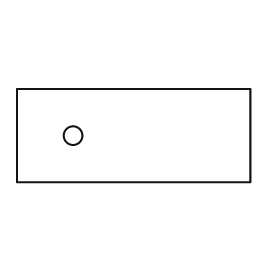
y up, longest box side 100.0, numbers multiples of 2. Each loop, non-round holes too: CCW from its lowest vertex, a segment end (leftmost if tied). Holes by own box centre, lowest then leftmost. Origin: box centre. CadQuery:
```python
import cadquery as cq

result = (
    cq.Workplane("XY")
    .moveTo(-50.0, -20.0)
    .lineTo(50.0, -20.0)
    .lineTo(50.0, 20.0)
    .lineTo(-50.0, 20.0)
    .close()
    .moveTo(-26.0, 0.0)
    .circle(4.0)
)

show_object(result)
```